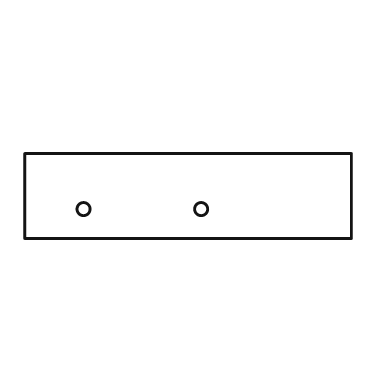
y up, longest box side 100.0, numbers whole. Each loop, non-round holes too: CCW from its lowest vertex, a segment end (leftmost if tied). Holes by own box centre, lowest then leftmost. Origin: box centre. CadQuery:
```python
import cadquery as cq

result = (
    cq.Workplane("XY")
    .moveTo(-50.0, -13.0)
    .lineTo(50.0, -13.0)
    .lineTo(50.0, 13.0)
    .lineTo(-50.0, 13.0)
    .close()
    .moveTo(-32.0, -4.0)
    .circle(2.0)
    .moveTo(4.0, -4.0)
    .circle(2.0)
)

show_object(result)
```